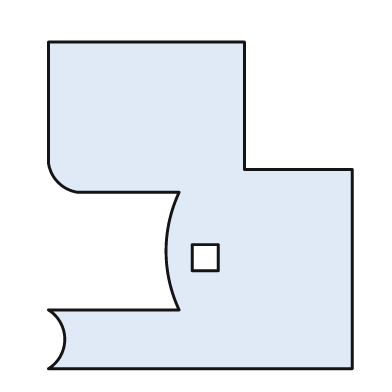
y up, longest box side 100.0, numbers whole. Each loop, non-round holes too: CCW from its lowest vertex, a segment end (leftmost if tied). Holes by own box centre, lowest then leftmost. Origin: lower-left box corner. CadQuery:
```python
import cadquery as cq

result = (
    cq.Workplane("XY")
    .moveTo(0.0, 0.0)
    .lineTo(93.0, 0.0)
    .lineTo(93.0, 61.0)
    .lineTo(60.0, 61.0)
    .lineTo(60.0, 100.0)
    .lineTo(0.0, 100.0)
    .lineTo(0.0, 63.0)
    .threePointArc((3.0, 57.0), (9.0, 54.0))
    .lineTo(40.0, 54.0)
    .threePointArc((36.0, 36.0), (40.0, 18.0))
    .lineTo(0.0, 18.0)
    .threePointArc((5.0, 9.0), (0.0, 0.0))
    .close()
    .moveTo(44.0, 30.0)
    .lineTo(52.0, 30.0)
    .lineTo(52.0, 38.0)
    .lineTo(44.0, 38.0)
    .close()
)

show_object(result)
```